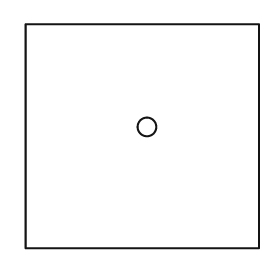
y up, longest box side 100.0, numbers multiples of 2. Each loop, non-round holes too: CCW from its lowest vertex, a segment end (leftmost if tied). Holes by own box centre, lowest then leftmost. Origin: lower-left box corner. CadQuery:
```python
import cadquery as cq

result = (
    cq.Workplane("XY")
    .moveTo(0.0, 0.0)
    .lineTo(100.0, 0.0)
    .lineTo(100.0, 96.0)
    .lineTo(0.0, 96.0)
    .close()
    .moveTo(52.0, 52.0)
    .circle(4.0)
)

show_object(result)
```